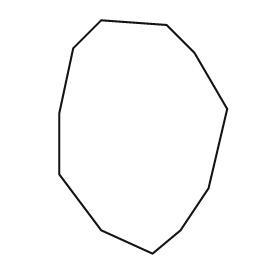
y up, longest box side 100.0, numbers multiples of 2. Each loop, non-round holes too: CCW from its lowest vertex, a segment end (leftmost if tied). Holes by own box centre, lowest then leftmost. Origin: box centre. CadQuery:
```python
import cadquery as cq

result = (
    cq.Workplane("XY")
    .moveTo(4.0, -50.0)
    .lineTo(16.0, -40.0)
    .lineTo(28.0, -22.0)
    .lineTo(36.0, 12.0)
    .lineTo(22.0, 36.0)
    .lineTo(10.0, 48.0)
    .lineTo(-18.0, 50.0)
    .lineTo(-30.0, 38.0)
    .lineTo(-36.0, 10.0)
    .lineTo(-36.0, -16.0)
    .lineTo(-18.0, -40.0)
    .close()
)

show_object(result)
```